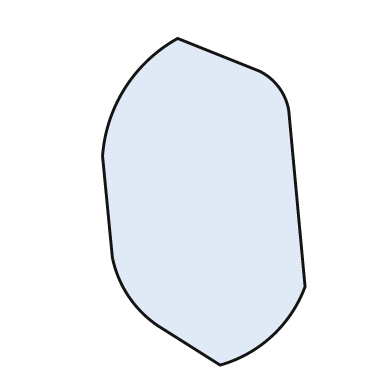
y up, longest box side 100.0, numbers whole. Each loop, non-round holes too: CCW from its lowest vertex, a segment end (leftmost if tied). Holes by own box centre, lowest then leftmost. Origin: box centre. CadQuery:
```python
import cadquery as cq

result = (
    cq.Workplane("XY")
    .moveTo(5.0, -50.0)
    .threePointArc((21.0, -41.0), (31.0, -26.0))
    .lineTo(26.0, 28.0)
    .threePointArc((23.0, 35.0), (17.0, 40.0))
    .lineTo(-8.0, 50.0)
    .threePointArc((-24.0, 35.0), (-31.0, 14.0))
    .lineTo(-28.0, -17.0)
    .threePointArc((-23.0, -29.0), (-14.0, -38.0))
    .close()
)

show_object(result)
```